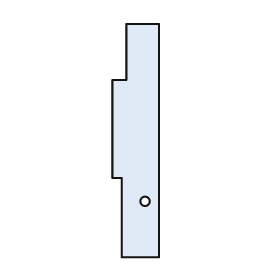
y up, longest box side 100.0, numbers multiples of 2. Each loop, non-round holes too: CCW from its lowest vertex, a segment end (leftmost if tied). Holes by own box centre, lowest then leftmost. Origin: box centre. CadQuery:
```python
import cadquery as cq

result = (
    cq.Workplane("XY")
    .moveTo(-6.0, -50.0)
    .lineTo(10.0, -50.0)
    .lineTo(10.0, 50.0)
    .lineTo(-4.0, 50.0)
    .lineTo(-4.0, 26.0)
    .lineTo(-10.0, 26.0)
    .lineTo(-10.0, -16.0)
    .lineTo(-6.0, -16.0)
    .close()
    .moveTo(4.0, -26.0)
    .circle(2.0)
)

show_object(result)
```